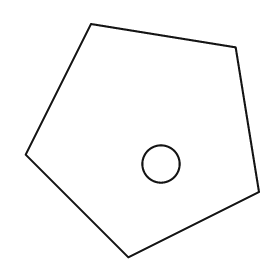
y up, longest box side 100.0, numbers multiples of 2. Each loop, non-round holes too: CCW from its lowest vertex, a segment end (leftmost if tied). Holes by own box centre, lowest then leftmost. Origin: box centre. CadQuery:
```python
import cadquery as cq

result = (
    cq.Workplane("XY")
    .moveTo(-6.0, -50.0)
    .lineTo(50.0, -22.0)
    .lineTo(40.0, 40.0)
    .lineTo(-22.0, 50.0)
    .lineTo(-50.0, -6.0)
    .close()
    .moveTo(8.0, -10.0)
    .circle(8.0)
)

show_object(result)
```